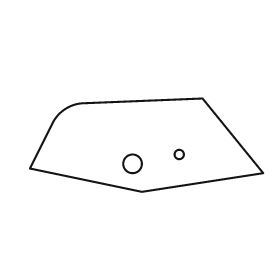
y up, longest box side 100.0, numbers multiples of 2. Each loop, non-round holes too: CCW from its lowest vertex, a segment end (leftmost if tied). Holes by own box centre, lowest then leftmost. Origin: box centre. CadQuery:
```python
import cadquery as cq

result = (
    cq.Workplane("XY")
    .moveTo(-2.0, -20.0)
    .lineTo(50.0, -12.0)
    .lineTo(24.0, 20.0)
    .lineTo(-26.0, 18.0)
    .threePointArc((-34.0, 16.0), (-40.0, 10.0))
    .lineTo(-50.0, -10.0)
    .close()
    .moveTo(-6.0, -8.0)
    .circle(4.0)
    .moveTo(14.0, -4.0)
    .circle(2.0)
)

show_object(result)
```